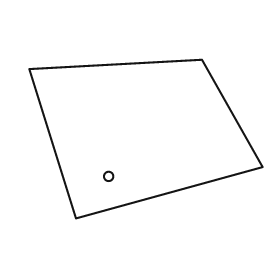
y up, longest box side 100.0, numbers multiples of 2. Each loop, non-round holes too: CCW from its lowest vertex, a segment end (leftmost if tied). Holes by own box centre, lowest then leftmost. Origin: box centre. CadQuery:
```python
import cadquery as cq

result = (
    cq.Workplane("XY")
    .moveTo(-30.0, -34.0)
    .lineTo(50.0, -12.0)
    .lineTo(24.0, 34.0)
    .lineTo(-50.0, 30.0)
    .close()
    .moveTo(-16.0, -16.0)
    .circle(2.0)
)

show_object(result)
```